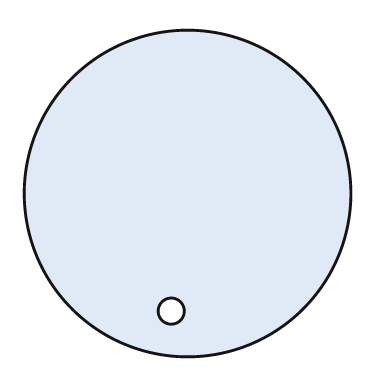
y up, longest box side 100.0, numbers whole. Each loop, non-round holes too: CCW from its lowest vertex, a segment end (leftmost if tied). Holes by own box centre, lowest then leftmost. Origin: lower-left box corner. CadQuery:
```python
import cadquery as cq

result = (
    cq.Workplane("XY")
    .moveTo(50.0, 50.0)
    .circle(50.0)
    .moveTo(45.0, 14.0)
    .circle(4.0)
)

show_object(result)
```